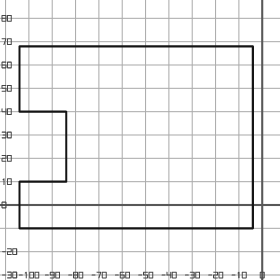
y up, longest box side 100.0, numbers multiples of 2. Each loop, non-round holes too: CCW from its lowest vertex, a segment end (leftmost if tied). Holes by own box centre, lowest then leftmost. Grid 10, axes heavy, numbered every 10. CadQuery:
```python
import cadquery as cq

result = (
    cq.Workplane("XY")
    .moveTo(-104.0, -10.0)
    .lineTo(-4.0, -10.0)
    .lineTo(-4.0, 68.0)
    .lineTo(-104.0, 68.0)
    .lineTo(-104.0, 40.0)
    .lineTo(-84.0, 40.0)
    .lineTo(-84.0, 10.0)
    .lineTo(-104.0, 10.0)
    .close()
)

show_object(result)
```